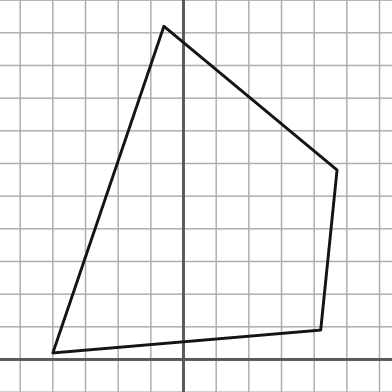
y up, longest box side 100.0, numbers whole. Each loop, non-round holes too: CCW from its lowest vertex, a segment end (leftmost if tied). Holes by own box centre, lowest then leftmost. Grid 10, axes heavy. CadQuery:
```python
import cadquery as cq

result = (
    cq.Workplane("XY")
    .moveTo(-40.0, 2.0)
    .lineTo(42.0, 9.0)
    .lineTo(47.0, 58.0)
    .lineTo(-6.0, 102.0)
    .close()
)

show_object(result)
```